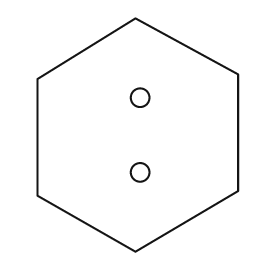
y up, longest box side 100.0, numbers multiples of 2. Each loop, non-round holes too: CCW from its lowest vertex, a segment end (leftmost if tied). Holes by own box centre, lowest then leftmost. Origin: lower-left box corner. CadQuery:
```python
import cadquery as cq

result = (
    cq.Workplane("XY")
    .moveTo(42.0, 0.0)
    .lineTo(86.0, 26.0)
    .lineTo(86.0, 76.0)
    .lineTo(42.0, 100.0)
    .lineTo(0.0, 74.0)
    .lineTo(0.0, 24.0)
    .close()
    .moveTo(44.0, 34.0)
    .circle(4.0)
    .moveTo(44.0, 66.0)
    .circle(4.0)
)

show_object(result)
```